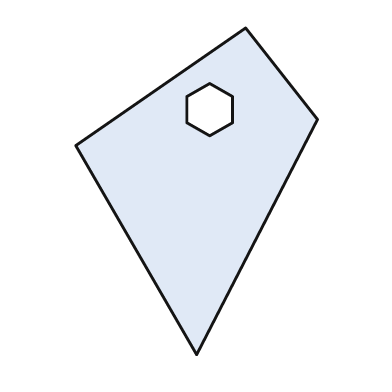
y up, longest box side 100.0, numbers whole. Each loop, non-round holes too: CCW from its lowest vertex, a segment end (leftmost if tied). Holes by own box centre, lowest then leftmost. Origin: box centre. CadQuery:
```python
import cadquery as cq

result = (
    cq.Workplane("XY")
    .moveTo(0.0, -50.0)
    .lineTo(37.0, 22.0)
    .lineTo(15.0, 50.0)
    .lineTo(-37.0, 14.0)
    .close()
    .moveTo(4.0, 17.0)
    .lineTo(11.0, 21.0)
    .lineTo(11.0, 29.0)
    .lineTo(4.0, 33.0)
    .lineTo(-3.0, 29.0)
    .lineTo(-3.0, 21.0)
    .close()
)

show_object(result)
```